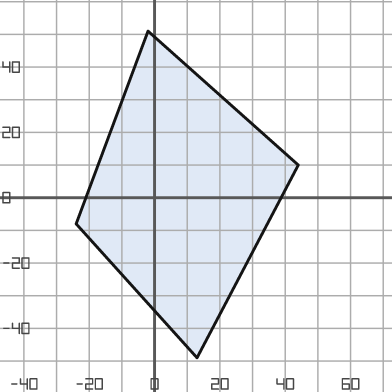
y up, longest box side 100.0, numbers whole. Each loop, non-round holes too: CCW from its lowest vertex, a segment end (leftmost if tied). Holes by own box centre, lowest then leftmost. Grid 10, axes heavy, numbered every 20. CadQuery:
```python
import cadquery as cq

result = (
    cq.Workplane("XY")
    .moveTo(13.0, -49.0)
    .lineTo(44.0, 10.0)
    .lineTo(-2.0, 51.0)
    .lineTo(-24.0, -8.0)
    .close()
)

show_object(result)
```